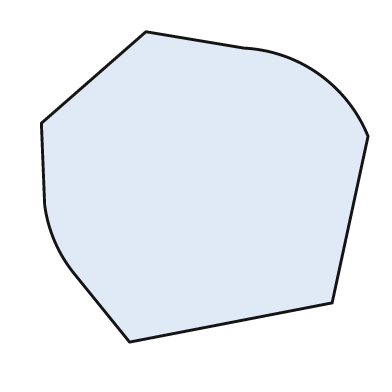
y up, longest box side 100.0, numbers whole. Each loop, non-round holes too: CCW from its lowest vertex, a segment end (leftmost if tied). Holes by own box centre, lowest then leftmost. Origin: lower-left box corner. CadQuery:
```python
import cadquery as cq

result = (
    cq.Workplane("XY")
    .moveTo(27.0, 0.0)
    .lineTo(89.0, 12.0)
    .lineTo(100.0, 63.0)
    .threePointArc((85.0, 82.0), (62.0, 90.0))
    .lineTo(32.0, 95.0)
    .lineTo(0.0, 67.0)
    .lineTo(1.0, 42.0)
    .threePointArc((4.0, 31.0), (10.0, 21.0))
    .close()
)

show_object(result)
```